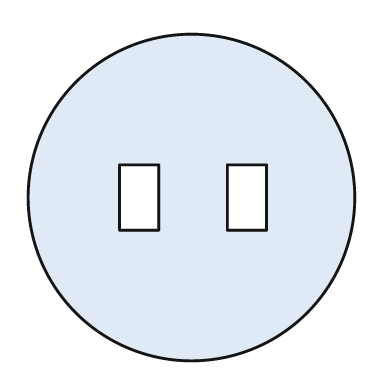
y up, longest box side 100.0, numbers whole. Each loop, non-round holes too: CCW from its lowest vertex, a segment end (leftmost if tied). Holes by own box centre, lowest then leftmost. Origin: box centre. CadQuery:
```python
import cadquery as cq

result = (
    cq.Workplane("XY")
    .moveTo(0.0, 0.0)
    .circle(50.0)
    .moveTo(-22.0, -10.0)
    .lineTo(-10.0, -10.0)
    .lineTo(-10.0, 10.0)
    .lineTo(-22.0, 10.0)
    .close()
    .moveTo(11.0, -10.0)
    .lineTo(23.0, -10.0)
    .lineTo(23.0, 10.0)
    .lineTo(11.0, 10.0)
    .close()
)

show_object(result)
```